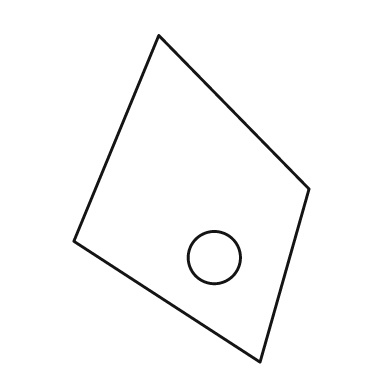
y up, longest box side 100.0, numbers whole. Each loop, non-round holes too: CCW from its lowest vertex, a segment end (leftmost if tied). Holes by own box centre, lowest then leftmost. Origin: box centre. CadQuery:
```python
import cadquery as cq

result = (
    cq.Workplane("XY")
    .moveTo(21.0, -50.0)
    .lineTo(36.0, 3.0)
    .lineTo(-10.0, 50.0)
    .lineTo(-36.0, -13.0)
    .close()
    .moveTo(7.0, -18.0)
    .circle(8.0)
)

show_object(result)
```